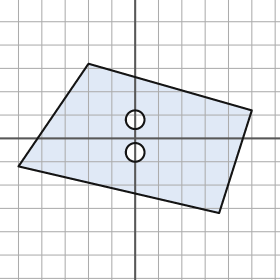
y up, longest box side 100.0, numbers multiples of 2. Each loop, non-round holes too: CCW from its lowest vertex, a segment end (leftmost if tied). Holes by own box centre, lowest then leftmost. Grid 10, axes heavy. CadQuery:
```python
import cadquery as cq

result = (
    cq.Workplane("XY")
    .moveTo(36.0, -32.0)
    .lineTo(50.0, 12.0)
    .lineTo(-20.0, 32.0)
    .lineTo(-50.0, -12.0)
    .close()
    .moveTo(0.0, -6.0)
    .circle(4.0)
    .moveTo(0.0, 8.0)
    .circle(4.0)
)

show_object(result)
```